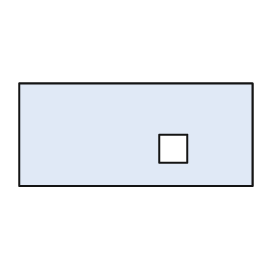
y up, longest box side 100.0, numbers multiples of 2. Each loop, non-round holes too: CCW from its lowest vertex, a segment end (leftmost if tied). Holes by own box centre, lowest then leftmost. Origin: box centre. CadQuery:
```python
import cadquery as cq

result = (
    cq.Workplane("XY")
    .moveTo(-50.0, -22.0)
    .lineTo(50.0, -22.0)
    .lineTo(50.0, 22.0)
    .lineTo(-50.0, 22.0)
    .close()
    .moveTo(10.0, -12.0)
    .lineTo(22.0, -12.0)
    .lineTo(22.0, 0.0)
    .lineTo(10.0, 0.0)
    .close()
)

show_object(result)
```